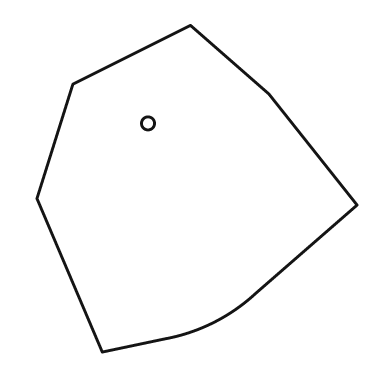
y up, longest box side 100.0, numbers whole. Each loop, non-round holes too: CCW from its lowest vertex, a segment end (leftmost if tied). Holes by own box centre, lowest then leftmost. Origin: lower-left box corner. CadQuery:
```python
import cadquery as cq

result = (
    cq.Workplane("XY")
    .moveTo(20.0, 0.0)
    .lineTo(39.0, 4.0)
    .threePointArc((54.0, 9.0), (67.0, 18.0))
    .lineTo(98.0, 45.0)
    .lineTo(71.0, 79.0)
    .lineTo(47.0, 100.0)
    .lineTo(11.0, 82.0)
    .lineTo(0.0, 47.0)
    .close()
    .moveTo(34.0, 70.0)
    .circle(2.0)
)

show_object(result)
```